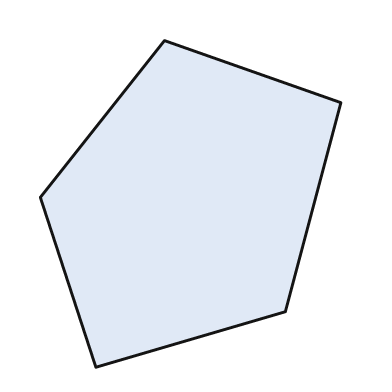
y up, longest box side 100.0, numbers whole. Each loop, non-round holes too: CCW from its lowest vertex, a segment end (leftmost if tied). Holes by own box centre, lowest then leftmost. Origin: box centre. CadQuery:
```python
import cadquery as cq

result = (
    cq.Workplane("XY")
    .moveTo(-29.0, -50.0)
    .lineTo(29.0, -33.0)
    .lineTo(46.0, 31.0)
    .lineTo(-8.0, 50.0)
    .lineTo(-46.0, 2.0)
    .close()
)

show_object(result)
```